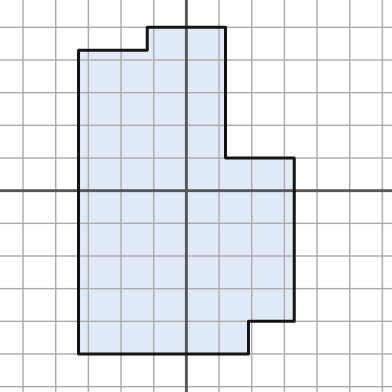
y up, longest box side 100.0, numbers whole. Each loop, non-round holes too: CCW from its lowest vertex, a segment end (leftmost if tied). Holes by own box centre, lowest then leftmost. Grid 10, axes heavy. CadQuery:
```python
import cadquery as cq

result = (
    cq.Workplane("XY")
    .moveTo(-33.0, -50.0)
    .lineTo(19.0, -50.0)
    .lineTo(19.0, -40.0)
    .lineTo(33.0, -40.0)
    .lineTo(33.0, 10.0)
    .lineTo(12.0, 10.0)
    .lineTo(12.0, 50.0)
    .lineTo(-12.0, 50.0)
    .lineTo(-12.0, 43.0)
    .lineTo(-33.0, 43.0)
    .close()
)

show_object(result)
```